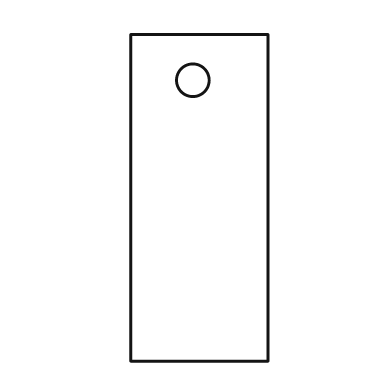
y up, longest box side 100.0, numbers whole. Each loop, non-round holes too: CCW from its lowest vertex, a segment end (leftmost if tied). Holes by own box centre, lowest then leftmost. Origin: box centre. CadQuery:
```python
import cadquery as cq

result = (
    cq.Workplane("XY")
    .moveTo(-21.0, -50.0)
    .lineTo(21.0, -50.0)
    .lineTo(21.0, 50.0)
    .lineTo(-21.0, 50.0)
    .close()
    .moveTo(-2.0, 36.0)
    .circle(5.0)
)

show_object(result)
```